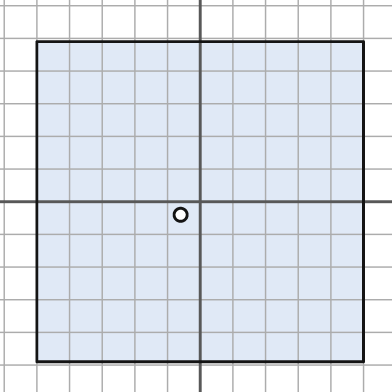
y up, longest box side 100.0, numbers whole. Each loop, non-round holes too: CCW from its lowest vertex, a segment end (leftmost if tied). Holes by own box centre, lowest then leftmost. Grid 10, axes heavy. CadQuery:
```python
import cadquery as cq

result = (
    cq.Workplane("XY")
    .moveTo(-50.0, -49.0)
    .lineTo(50.0, -49.0)
    .lineTo(50.0, 49.0)
    .lineTo(-50.0, 49.0)
    .close()
    .moveTo(-6.0, -4.0)
    .circle(2.0)
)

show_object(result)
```